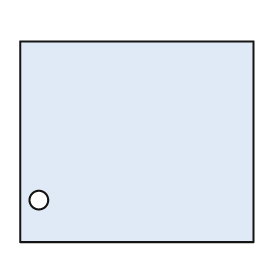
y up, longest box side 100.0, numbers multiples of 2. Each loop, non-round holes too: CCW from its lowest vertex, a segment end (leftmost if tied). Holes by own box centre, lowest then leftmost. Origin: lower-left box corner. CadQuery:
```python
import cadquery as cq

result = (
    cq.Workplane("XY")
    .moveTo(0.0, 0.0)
    .lineTo(100.0, 0.0)
    .lineTo(100.0, 86.0)
    .lineTo(0.0, 86.0)
    .close()
    .moveTo(8.0, 18.0)
    .circle(4.0)
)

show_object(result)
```